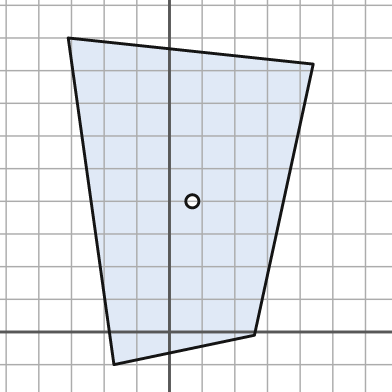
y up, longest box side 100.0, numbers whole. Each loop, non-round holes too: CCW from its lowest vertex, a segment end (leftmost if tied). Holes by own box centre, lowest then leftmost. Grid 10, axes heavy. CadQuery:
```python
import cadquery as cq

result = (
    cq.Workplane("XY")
    .moveTo(-17.0, -10.0)
    .lineTo(26.0, -1.0)
    .lineTo(44.0, 82.0)
    .lineTo(-31.0, 90.0)
    .close()
    .moveTo(7.0, 40.0)
    .circle(2.0)
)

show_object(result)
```